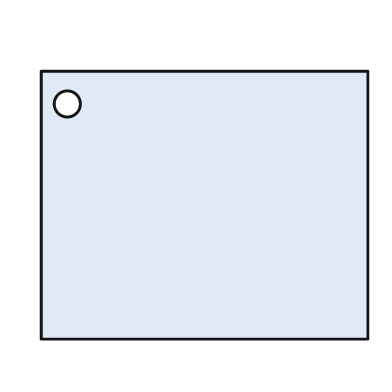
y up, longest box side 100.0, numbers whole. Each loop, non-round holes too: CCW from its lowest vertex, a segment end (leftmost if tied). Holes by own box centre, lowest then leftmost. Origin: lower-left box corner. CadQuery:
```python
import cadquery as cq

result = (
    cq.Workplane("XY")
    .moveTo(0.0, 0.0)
    .lineTo(100.0, 0.0)
    .lineTo(100.0, 82.0)
    .lineTo(0.0, 82.0)
    .close()
    .moveTo(8.0, 72.0)
    .circle(4.0)
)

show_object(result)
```